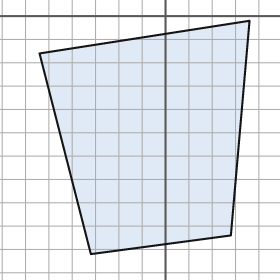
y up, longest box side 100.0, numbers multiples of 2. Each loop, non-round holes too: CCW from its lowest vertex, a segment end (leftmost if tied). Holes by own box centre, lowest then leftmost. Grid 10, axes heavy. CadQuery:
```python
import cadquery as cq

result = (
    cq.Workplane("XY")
    .moveTo(-32.0, -102.0)
    .lineTo(28.0, -94.0)
    .lineTo(36.0, -2.0)
    .lineTo(-54.0, -16.0)
    .close()
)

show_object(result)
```